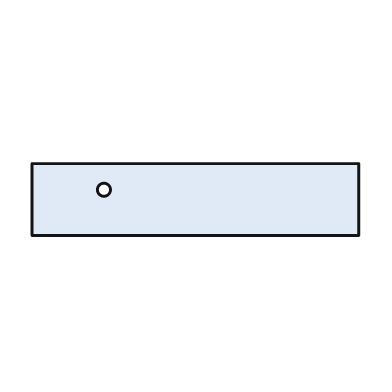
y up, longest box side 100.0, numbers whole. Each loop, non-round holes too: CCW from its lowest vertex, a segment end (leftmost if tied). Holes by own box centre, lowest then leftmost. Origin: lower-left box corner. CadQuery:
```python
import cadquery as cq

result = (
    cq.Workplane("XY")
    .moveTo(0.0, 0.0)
    .lineTo(100.0, 0.0)
    .lineTo(100.0, 22.0)
    .lineTo(0.0, 22.0)
    .close()
    .moveTo(22.0, 14.0)
    .circle(2.0)
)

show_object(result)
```